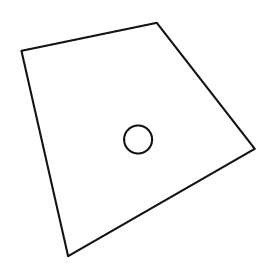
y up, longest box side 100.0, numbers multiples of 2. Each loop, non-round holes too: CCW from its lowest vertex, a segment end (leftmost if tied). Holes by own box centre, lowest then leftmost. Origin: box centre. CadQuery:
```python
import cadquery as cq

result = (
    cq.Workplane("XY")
    .moveTo(-30.0, -50.0)
    .lineTo(50.0, -4.0)
    .lineTo(8.0, 50.0)
    .lineTo(-50.0, 38.0)
    .close()
    .moveTo(0.0, 0.0)
    .circle(6.0)
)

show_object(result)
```